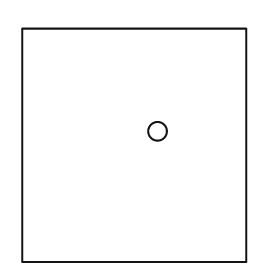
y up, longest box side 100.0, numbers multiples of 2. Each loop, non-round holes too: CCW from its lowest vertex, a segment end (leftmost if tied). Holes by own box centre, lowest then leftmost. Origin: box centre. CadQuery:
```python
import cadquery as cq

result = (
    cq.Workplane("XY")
    .moveTo(-48.0, -50.0)
    .lineTo(48.0, -50.0)
    .lineTo(48.0, 50.0)
    .lineTo(-48.0, 50.0)
    .close()
    .moveTo(10.0, 6.0)
    .circle(4.0)
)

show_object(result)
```